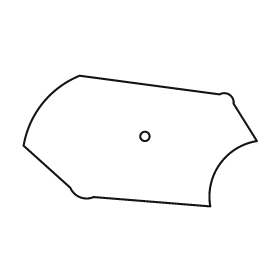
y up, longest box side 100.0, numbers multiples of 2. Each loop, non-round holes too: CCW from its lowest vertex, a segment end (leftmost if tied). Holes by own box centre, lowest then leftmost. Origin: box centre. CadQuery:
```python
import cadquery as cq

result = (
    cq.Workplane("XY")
    .moveTo(30.0, -28.0)
    .threePointArc((34.0, -10.0), (50.0, 0.0))
    .lineTo(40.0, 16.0)
    .threePointArc((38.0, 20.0), (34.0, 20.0))
    .lineTo(-26.0, 28.0)
    .threePointArc((-42.0, 16.0), (-50.0, -2.0))
    .lineTo(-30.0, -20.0)
    .threePointArc((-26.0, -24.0), (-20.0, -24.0))
    .close()
    .moveTo(2.0, 2.0)
    .circle(2.0)
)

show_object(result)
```